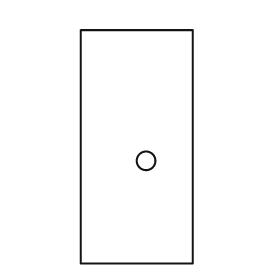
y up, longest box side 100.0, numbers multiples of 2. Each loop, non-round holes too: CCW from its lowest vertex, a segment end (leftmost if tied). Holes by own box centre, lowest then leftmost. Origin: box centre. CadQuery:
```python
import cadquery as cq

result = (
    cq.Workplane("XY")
    .moveTo(-24.0, -50.0)
    .lineTo(24.0, -50.0)
    .lineTo(24.0, 50.0)
    .lineTo(-24.0, 50.0)
    .close()
    .moveTo(4.0, -6.0)
    .circle(4.0)
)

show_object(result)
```